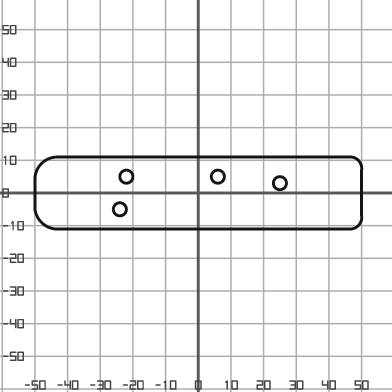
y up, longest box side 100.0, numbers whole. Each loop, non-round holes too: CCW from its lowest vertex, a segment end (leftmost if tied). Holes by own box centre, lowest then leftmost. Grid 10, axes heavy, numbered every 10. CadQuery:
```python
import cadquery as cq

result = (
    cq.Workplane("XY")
    .moveTo(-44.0, -11.0)
    .lineTo(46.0, -11.0)
    .threePointArc((49.0, -10.0), (50.0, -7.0))
    .lineTo(50.0, 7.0)
    .threePointArc((49.0, 10.0), (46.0, 11.0))
    .lineTo(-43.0, 11.0)
    .threePointArc((-48.0, 9.0), (-50.0, 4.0))
    .lineTo(-50.0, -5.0)
    .threePointArc((-48.0, -9.0), (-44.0, -11.0))
    .close()
    .moveTo(-24.0, -5.0)
    .circle(2.0)
    .moveTo(25.0, 3.0)
    .circle(2.0)
    .moveTo(-22.0, 5.0)
    .circle(2.0)
    .moveTo(6.0, 5.0)
    .circle(2.0)
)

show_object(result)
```